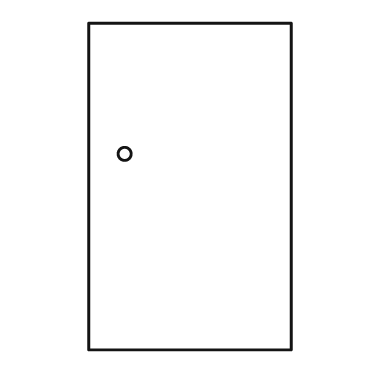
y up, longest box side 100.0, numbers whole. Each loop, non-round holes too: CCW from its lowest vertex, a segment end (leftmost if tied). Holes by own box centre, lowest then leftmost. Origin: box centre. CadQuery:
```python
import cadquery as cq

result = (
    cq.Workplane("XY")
    .moveTo(-31.0, -50.0)
    .lineTo(31.0, -50.0)
    .lineTo(31.0, 50.0)
    .lineTo(-31.0, 50.0)
    .close()
    .moveTo(-20.0, 10.0)
    .circle(2.0)
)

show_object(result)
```